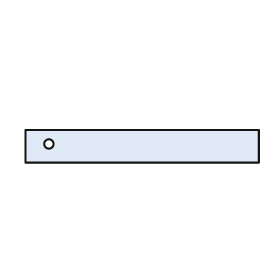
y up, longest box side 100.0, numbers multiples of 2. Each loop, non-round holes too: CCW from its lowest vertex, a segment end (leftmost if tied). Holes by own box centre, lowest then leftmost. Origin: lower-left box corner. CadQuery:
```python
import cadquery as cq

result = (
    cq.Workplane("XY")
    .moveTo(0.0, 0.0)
    .lineTo(100.0, 0.0)
    .lineTo(100.0, 14.0)
    .lineTo(0.0, 14.0)
    .close()
    .moveTo(10.0, 8.0)
    .circle(2.0)
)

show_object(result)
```